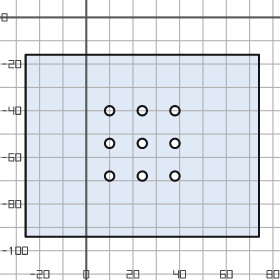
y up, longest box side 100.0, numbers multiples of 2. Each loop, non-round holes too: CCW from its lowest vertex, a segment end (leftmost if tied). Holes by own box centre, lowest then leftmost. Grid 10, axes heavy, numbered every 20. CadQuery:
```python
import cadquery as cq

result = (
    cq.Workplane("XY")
    .moveTo(-26.0, -94.0)
    .lineTo(74.0, -94.0)
    .lineTo(74.0, -16.0)
    .lineTo(-26.0, -16.0)
    .close()
    .moveTo(10.0, -68.0)
    .circle(2.0)
    .moveTo(24.0, -68.0)
    .circle(2.0)
    .moveTo(38.0, -68.0)
    .circle(2.0)
    .moveTo(10.0, -54.0)
    .circle(2.0)
    .moveTo(24.0, -54.0)
    .circle(2.0)
    .moveTo(38.0, -54.0)
    .circle(2.0)
    .moveTo(10.0, -40.0)
    .circle(2.0)
    .moveTo(24.0, -40.0)
    .circle(2.0)
    .moveTo(38.0, -40.0)
    .circle(2.0)
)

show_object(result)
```